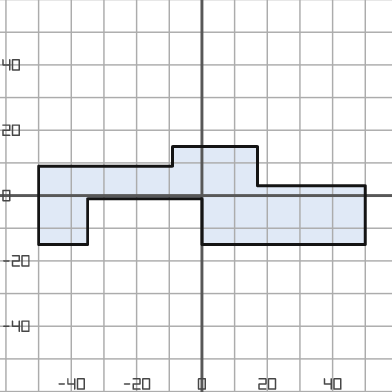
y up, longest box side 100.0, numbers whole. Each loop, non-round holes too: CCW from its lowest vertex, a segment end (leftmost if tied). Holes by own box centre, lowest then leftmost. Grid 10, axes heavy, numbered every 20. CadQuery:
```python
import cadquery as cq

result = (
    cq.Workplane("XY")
    .moveTo(-50.0, -15.0)
    .lineTo(-35.0, -15.0)
    .lineTo(-35.0, -1.0)
    .lineTo(0.0, -1.0)
    .lineTo(0.0, -15.0)
    .lineTo(50.0, -15.0)
    .lineTo(50.0, 3.0)
    .lineTo(17.0, 3.0)
    .lineTo(17.0, 15.0)
    .lineTo(-9.0, 15.0)
    .lineTo(-9.0, 9.0)
    .lineTo(-50.0, 9.0)
    .close()
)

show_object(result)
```